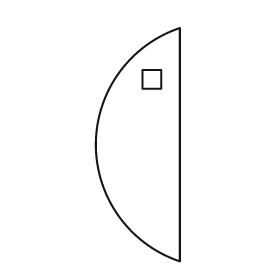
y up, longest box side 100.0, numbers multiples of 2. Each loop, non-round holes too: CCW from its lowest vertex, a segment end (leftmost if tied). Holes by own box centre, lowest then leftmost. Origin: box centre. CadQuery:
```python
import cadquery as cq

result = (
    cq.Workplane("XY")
    .moveTo(18.0, -50.0)
    .lineTo(18.0, 50.0)
    .threePointArc((-18.0, 0.0), (18.0, -50.0))
    .close()
    .moveTo(2.0, 24.0)
    .lineTo(10.0, 24.0)
    .lineTo(10.0, 32.0)
    .lineTo(2.0, 32.0)
    .close()
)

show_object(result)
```